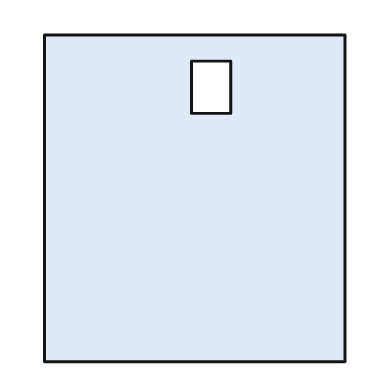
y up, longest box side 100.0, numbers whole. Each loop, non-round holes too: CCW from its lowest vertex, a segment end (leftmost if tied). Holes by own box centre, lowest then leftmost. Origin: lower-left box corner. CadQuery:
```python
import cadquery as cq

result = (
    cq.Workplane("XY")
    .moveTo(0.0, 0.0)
    .lineTo(92.0, 0.0)
    .lineTo(92.0, 100.0)
    .lineTo(0.0, 100.0)
    .close()
    .moveTo(45.0, 76.0)
    .lineTo(57.0, 76.0)
    .lineTo(57.0, 92.0)
    .lineTo(45.0, 92.0)
    .close()
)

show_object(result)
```